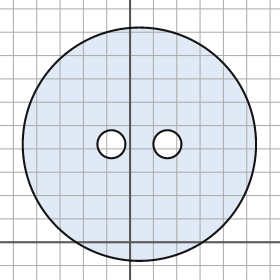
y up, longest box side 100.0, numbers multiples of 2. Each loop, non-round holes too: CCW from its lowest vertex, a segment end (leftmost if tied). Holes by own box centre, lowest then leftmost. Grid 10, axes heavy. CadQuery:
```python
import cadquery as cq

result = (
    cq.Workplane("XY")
    .moveTo(4.0, 42.0)
    .circle(50.0)
    .moveTo(-8.0, 42.0)
    .circle(6.0)
    .moveTo(16.0, 42.0)
    .circle(6.0)
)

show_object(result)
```